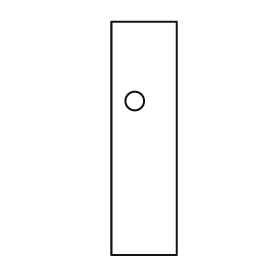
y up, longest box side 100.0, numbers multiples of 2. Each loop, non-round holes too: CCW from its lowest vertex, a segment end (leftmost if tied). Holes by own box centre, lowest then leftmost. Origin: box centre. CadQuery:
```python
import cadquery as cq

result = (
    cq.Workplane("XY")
    .moveTo(-14.0, -50.0)
    .lineTo(14.0, -50.0)
    .lineTo(14.0, 50.0)
    .lineTo(-14.0, 50.0)
    .close()
    .moveTo(-4.0, 16.0)
    .circle(4.0)
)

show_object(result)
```